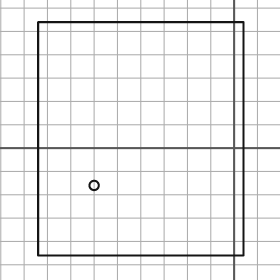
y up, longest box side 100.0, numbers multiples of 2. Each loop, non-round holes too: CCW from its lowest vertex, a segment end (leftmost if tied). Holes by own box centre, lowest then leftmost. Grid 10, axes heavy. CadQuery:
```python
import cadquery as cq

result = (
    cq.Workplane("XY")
    .moveTo(-84.0, -46.0)
    .lineTo(4.0, -46.0)
    .lineTo(4.0, 54.0)
    .lineTo(-84.0, 54.0)
    .close()
    .moveTo(-60.0, -16.0)
    .circle(2.0)
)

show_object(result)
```